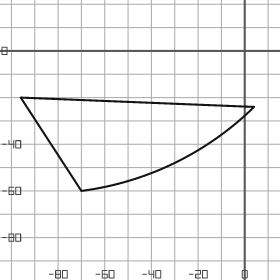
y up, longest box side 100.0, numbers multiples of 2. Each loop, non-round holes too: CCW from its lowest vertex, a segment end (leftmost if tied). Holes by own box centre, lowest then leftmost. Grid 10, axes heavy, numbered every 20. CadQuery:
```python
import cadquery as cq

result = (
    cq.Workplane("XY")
    .moveTo(-70.0, -60.0)
    .threePointArc((-30.0, -48.0), (4.0, -24.0))
    .lineTo(-96.0, -20.0)
    .close()
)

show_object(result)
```